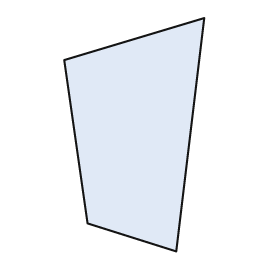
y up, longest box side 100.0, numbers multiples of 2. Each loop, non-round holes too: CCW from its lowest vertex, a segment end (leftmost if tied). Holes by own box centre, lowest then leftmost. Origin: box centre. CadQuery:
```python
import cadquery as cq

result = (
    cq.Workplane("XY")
    .moveTo(18.0, -50.0)
    .lineTo(30.0, 50.0)
    .lineTo(-30.0, 32.0)
    .lineTo(-20.0, -38.0)
    .close()
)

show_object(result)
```